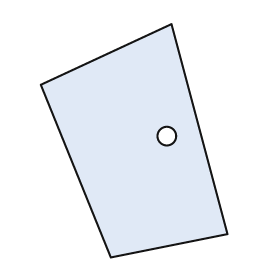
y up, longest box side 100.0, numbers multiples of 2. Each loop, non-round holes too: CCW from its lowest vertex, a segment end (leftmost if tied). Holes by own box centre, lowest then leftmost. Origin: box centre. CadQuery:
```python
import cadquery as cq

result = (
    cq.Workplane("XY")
    .moveTo(-10.0, -50.0)
    .lineTo(40.0, -40.0)
    .lineTo(16.0, 50.0)
    .lineTo(-40.0, 24.0)
    .close()
    .moveTo(14.0, 2.0)
    .circle(4.0)
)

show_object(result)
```